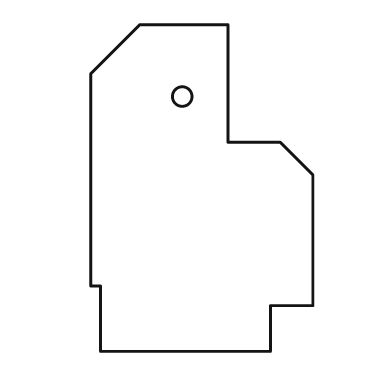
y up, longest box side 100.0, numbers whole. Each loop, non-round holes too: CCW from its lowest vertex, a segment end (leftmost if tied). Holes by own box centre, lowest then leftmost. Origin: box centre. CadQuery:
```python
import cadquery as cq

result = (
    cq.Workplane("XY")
    .moveTo(-31.0, -50.0)
    .lineTo(21.0, -50.0)
    .lineTo(21.0, -36.0)
    .lineTo(34.0, -36.0)
    .lineTo(34.0, 4.0)
    .lineTo(24.0, 14.0)
    .lineTo(8.0, 14.0)
    .lineTo(8.0, 50.0)
    .lineTo(-19.0, 50.0)
    .lineTo(-34.0, 35.0)
    .lineTo(-34.0, -30.0)
    .lineTo(-31.0, -30.0)
    .close()
    .moveTo(-6.0, 28.0)
    .circle(3.0)
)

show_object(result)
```